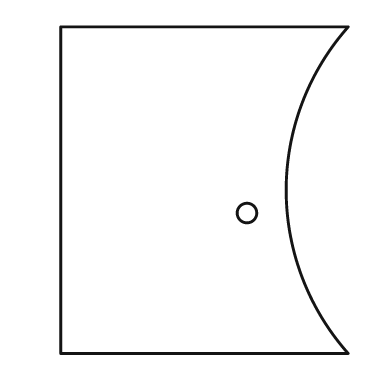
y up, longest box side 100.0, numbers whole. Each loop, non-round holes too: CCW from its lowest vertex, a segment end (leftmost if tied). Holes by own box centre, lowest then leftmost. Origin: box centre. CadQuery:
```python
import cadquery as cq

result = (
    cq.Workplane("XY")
    .moveTo(-44.0, -50.0)
    .lineTo(44.0, -50.0)
    .threePointArc((25.0, 0.0), (44.0, 50.0))
    .lineTo(-44.0, 50.0)
    .close()
    .moveTo(13.0, -7.0)
    .circle(3.0)
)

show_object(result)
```